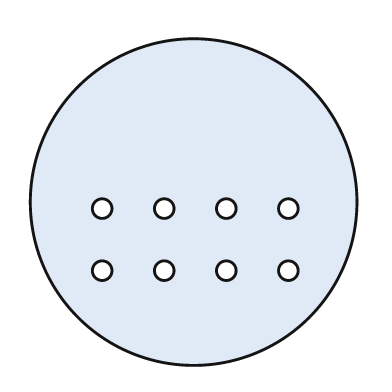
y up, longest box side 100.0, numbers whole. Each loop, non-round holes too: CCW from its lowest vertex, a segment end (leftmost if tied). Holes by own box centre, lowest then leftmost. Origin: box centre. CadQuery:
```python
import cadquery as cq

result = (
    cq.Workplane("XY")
    .moveTo(0.0, 0.0)
    .circle(50.0)
    .moveTo(-28.0, -21.0)
    .circle(3.0)
    .moveTo(-9.0, -21.0)
    .circle(3.0)
    .moveTo(10.0, -21.0)
    .circle(3.0)
    .moveTo(29.0, -21.0)
    .circle(3.0)
    .moveTo(-28.0, -2.0)
    .circle(3.0)
    .moveTo(-9.0, -2.0)
    .circle(3.0)
    .moveTo(10.0, -2.0)
    .circle(3.0)
    .moveTo(29.0, -2.0)
    .circle(3.0)
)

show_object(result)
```